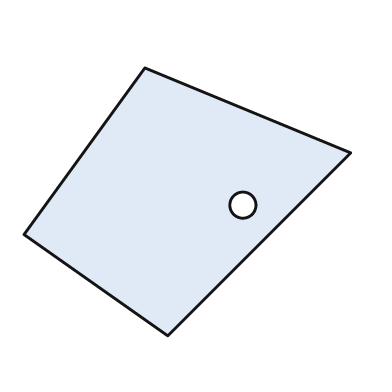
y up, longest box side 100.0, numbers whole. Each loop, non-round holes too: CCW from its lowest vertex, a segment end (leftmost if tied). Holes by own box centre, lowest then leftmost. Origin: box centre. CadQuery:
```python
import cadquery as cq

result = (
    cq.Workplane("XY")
    .moveTo(-6.0, -41.0)
    .lineTo(50.0, 15.0)
    .lineTo(-13.0, 41.0)
    .lineTo(-50.0, -10.0)
    .close()
    .moveTo(17.0, -1.0)
    .circle(4.0)
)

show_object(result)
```